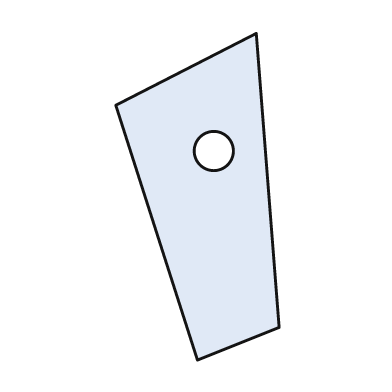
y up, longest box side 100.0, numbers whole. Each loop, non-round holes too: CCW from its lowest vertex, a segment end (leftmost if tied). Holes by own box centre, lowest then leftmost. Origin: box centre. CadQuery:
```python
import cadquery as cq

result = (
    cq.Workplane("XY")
    .moveTo(0.0, -50.0)
    .lineTo(25.0, -40.0)
    .lineTo(18.0, 50.0)
    .lineTo(-25.0, 28.0)
    .close()
    .moveTo(5.0, 14.0)
    .circle(6.0)
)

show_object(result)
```